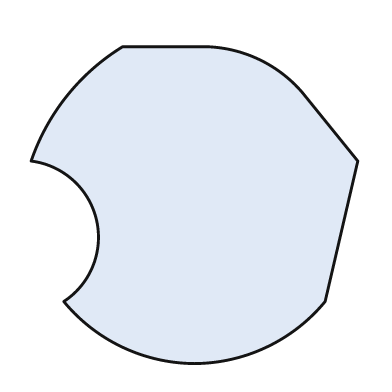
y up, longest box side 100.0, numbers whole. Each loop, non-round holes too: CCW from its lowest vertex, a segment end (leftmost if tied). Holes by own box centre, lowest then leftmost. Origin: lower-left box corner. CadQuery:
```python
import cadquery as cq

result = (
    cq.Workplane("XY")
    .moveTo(50.0, 0.0)
    .threePointArc((72.0, 5.0), (90.0, 19.0))
    .lineTo(100.0, 62.0)
    .lineTo(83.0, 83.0)
    .threePointArc((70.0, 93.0), (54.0, 97.0))
    .lineTo(28.0, 97.0)
    .threePointArc((11.0, 82.0), (0.0, 62.0))
    .threePointArc((20.0, 44.0), (10.0, 19.0))
    .threePointArc((28.0, 5.0), (50.0, 0.0))
    .close()
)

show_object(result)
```